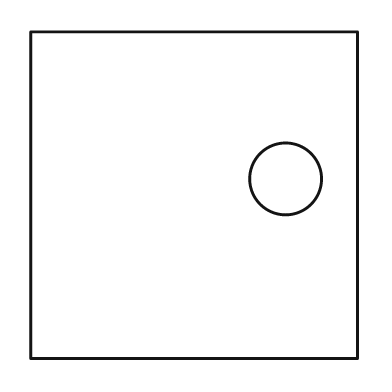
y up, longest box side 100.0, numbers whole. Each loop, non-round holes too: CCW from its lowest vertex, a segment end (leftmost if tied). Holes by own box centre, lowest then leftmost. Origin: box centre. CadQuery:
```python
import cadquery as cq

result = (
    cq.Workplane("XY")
    .moveTo(-50.0, -50.0)
    .lineTo(50.0, -50.0)
    .lineTo(50.0, 50.0)
    .lineTo(-50.0, 50.0)
    .close()
    .moveTo(28.0, 5.0)
    .circle(11.0)
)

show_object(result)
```